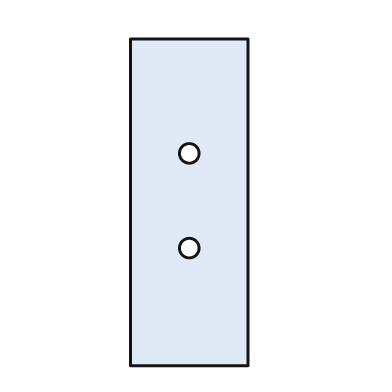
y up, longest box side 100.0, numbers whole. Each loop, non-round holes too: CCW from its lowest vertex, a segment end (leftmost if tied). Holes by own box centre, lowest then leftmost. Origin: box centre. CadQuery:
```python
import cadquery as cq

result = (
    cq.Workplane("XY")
    .moveTo(-18.0, -50.0)
    .lineTo(18.0, -50.0)
    .lineTo(18.0, 50.0)
    .lineTo(-18.0, 50.0)
    .close()
    .moveTo(0.0, -14.0)
    .circle(3.0)
    .moveTo(0.0, 15.0)
    .circle(3.0)
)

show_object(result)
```